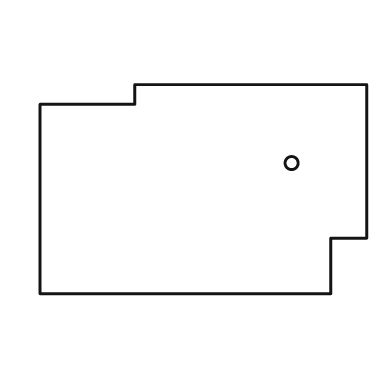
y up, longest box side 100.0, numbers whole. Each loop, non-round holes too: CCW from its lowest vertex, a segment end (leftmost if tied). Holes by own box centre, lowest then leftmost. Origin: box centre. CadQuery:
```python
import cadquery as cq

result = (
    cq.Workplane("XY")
    .moveTo(-50.0, -32.0)
    .lineTo(39.0, -32.0)
    .lineTo(39.0, -15.0)
    .lineTo(50.0, -15.0)
    .lineTo(50.0, 32.0)
    .lineTo(-21.0, 32.0)
    .lineTo(-21.0, 26.0)
    .lineTo(-50.0, 26.0)
    .close()
    .moveTo(27.0, 8.0)
    .circle(2.0)
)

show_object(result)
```